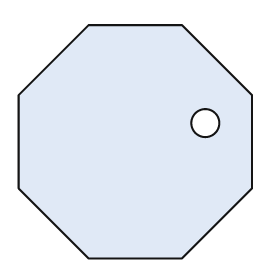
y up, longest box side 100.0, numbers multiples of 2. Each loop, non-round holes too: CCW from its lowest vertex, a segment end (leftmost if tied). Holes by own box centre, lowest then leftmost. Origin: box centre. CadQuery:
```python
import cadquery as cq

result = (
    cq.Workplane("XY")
    .moveTo(-20.0, -50.0)
    .lineTo(20.0, -50.0)
    .lineTo(50.0, -20.0)
    .lineTo(50.0, 20.0)
    .lineTo(20.0, 50.0)
    .lineTo(-20.0, 50.0)
    .lineTo(-50.0, 20.0)
    .lineTo(-50.0, -20.0)
    .close()
    .moveTo(30.0, 8.0)
    .circle(6.0)
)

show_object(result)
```